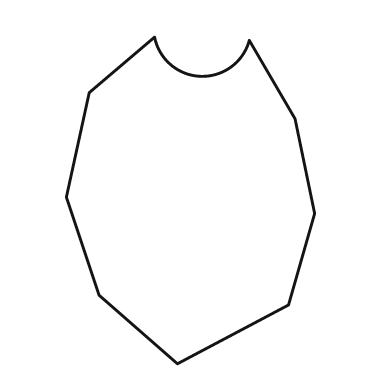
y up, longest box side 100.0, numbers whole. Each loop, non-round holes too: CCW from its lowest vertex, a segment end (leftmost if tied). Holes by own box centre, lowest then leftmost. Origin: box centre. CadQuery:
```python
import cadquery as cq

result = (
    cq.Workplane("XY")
    .moveTo(-4.0, -50.0)
    .lineTo(30.0, -32.0)
    .lineTo(38.0, -4.0)
    .lineTo(32.0, 25.0)
    .lineTo(18.0, 49.0)
    .threePointArc((3.0, 38.0), (-11.0, 50.0))
    .lineTo(-31.0, 33.0)
    .lineTo(-38.0, 1.0)
    .lineTo(-28.0, -29.0)
    .close()
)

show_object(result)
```